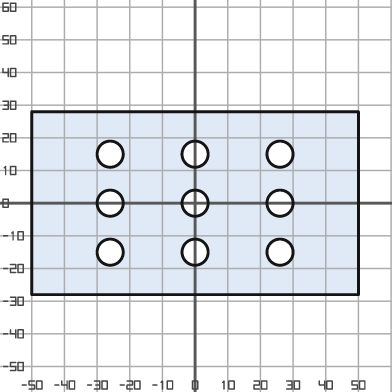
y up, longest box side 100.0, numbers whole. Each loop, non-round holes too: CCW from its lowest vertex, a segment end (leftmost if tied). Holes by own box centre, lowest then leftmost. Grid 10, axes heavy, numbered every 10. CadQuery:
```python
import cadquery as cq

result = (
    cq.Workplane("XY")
    .moveTo(-50.0, -28.0)
    .lineTo(50.0, -28.0)
    .lineTo(50.0, 28.0)
    .lineTo(-50.0, 28.0)
    .close()
    .moveTo(-26.0, -15.0)
    .circle(4.0)
    .moveTo(0.0, -15.0)
    .circle(4.0)
    .moveTo(26.0, -15.0)
    .circle(4.0)
    .moveTo(-26.0, 0.0)
    .circle(4.0)
    .moveTo(0.0, 0.0)
    .circle(4.0)
    .moveTo(26.0, 0.0)
    .circle(4.0)
    .moveTo(-26.0, 15.0)
    .circle(4.0)
    .moveTo(0.0, 15.0)
    .circle(4.0)
    .moveTo(26.0, 15.0)
    .circle(4.0)
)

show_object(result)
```